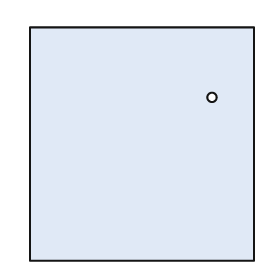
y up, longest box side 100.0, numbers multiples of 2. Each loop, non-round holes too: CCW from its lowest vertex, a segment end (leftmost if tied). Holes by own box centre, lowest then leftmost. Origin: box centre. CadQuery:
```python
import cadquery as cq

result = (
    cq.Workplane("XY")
    .moveTo(-48.0, -50.0)
    .lineTo(48.0, -50.0)
    .lineTo(48.0, 50.0)
    .lineTo(-48.0, 50.0)
    .close()
    .moveTo(30.0, 20.0)
    .circle(2.0)
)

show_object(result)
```